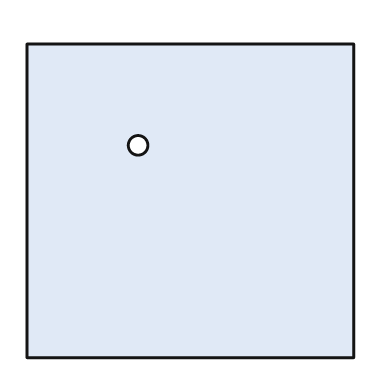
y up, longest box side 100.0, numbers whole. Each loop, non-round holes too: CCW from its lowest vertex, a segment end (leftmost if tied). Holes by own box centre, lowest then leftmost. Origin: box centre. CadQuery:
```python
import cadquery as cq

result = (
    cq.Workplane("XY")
    .moveTo(-50.0, -48.0)
    .lineTo(50.0, -48.0)
    .lineTo(50.0, 48.0)
    .lineTo(-50.0, 48.0)
    .close()
    .moveTo(-16.0, 17.0)
    .circle(3.0)
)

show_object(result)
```